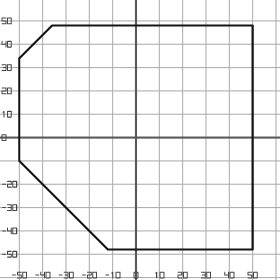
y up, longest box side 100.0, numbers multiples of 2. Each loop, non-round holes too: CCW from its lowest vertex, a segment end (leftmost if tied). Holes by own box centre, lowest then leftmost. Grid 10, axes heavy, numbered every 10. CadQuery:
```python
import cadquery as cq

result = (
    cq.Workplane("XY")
    .moveTo(-12.0, -48.0)
    .lineTo(50.0, -48.0)
    .lineTo(50.0, 48.0)
    .lineTo(-36.0, 48.0)
    .lineTo(-50.0, 34.0)
    .lineTo(-50.0, -10.0)
    .close()
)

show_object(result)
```